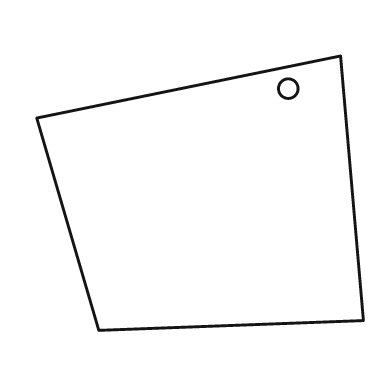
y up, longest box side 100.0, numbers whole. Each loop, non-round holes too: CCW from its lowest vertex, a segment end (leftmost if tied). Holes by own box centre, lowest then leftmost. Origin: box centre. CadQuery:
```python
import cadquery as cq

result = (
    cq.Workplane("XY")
    .moveTo(-31.0, -42.0)
    .lineTo(50.0, -39.0)
    .lineTo(43.0, 42.0)
    .lineTo(-50.0, 23.0)
    .close()
    .moveTo(27.0, 32.0)
    .circle(3.0)
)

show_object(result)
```